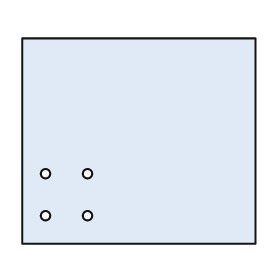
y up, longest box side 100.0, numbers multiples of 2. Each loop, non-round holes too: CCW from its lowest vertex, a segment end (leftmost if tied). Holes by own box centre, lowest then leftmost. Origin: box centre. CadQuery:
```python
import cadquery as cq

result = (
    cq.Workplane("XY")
    .moveTo(-50.0, -44.0)
    .lineTo(50.0, -44.0)
    .lineTo(50.0, 44.0)
    .lineTo(-50.0, 44.0)
    .close()
    .moveTo(-40.0, -32.0)
    .circle(2.0)
    .moveTo(-22.0, -32.0)
    .circle(2.0)
    .moveTo(-40.0, -14.0)
    .circle(2.0)
    .moveTo(-22.0, -14.0)
    .circle(2.0)
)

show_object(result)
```